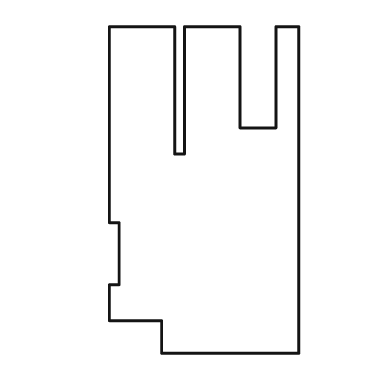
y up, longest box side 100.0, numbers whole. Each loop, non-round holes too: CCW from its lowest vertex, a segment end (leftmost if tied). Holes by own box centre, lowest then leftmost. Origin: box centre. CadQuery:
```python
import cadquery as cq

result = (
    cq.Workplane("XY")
    .moveTo(-13.0, -50.0)
    .lineTo(29.0, -50.0)
    .lineTo(29.0, 50.0)
    .lineTo(22.0, 50.0)
    .lineTo(22.0, 19.0)
    .lineTo(11.0, 19.0)
    .lineTo(11.0, 50.0)
    .lineTo(-6.0, 50.0)
    .lineTo(-6.0, 11.0)
    .lineTo(-9.0, 11.0)
    .lineTo(-9.0, 50.0)
    .lineTo(-29.0, 50.0)
    .lineTo(-29.0, -10.0)
    .lineTo(-26.0, -10.0)
    .lineTo(-26.0, -29.0)
    .lineTo(-29.0, -29.0)
    .lineTo(-29.0, -40.0)
    .lineTo(-13.0, -40.0)
    .close()
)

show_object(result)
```